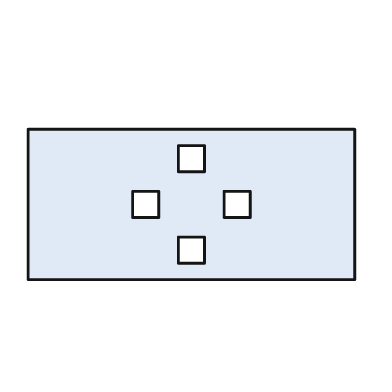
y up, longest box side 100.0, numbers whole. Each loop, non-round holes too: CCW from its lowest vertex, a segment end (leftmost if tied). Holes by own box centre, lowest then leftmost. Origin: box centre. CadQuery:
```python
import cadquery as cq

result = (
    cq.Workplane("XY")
    .moveTo(-50.0, -23.0)
    .lineTo(50.0, -23.0)
    .lineTo(50.0, 23.0)
    .lineTo(-50.0, 23.0)
    .close()
    .moveTo(-4.0, -18.0)
    .lineTo(4.0, -18.0)
    .lineTo(4.0, -10.0)
    .lineTo(-4.0, -10.0)
    .close()
    .moveTo(-18.0, -4.0)
    .lineTo(-10.0, -4.0)
    .lineTo(-10.0, 4.0)
    .lineTo(-18.0, 4.0)
    .close()
    .moveTo(10.0, -4.0)
    .lineTo(18.0, -4.0)
    .lineTo(18.0, 4.0)
    .lineTo(10.0, 4.0)
    .close()
    .moveTo(-4.0, 10.0)
    .lineTo(4.0, 10.0)
    .lineTo(4.0, 18.0)
    .lineTo(-4.0, 18.0)
    .close()
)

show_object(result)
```